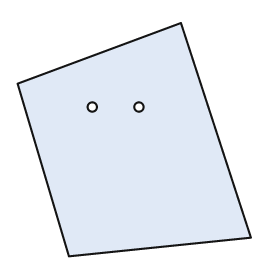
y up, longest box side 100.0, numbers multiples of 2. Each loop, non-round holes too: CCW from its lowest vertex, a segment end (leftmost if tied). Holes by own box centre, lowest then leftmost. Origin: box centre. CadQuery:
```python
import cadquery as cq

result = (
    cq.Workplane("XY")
    .moveTo(-28.0, -50.0)
    .lineTo(50.0, -42.0)
    .lineTo(20.0, 50.0)
    .lineTo(-50.0, 24.0)
    .close()
    .moveTo(-18.0, 14.0)
    .circle(2.0)
    .moveTo(2.0, 14.0)
    .circle(2.0)
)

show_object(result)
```